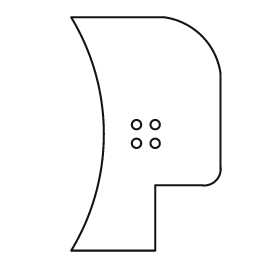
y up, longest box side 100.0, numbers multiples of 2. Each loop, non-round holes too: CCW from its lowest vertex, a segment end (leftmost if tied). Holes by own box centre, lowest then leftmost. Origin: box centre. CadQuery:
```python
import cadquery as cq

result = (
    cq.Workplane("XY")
    .moveTo(-32.0, -50.0)
    .lineTo(4.0, -50.0)
    .lineTo(4.0, -22.0)
    .lineTo(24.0, -22.0)
    .threePointArc((30.0, -20.0), (32.0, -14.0))
    .lineTo(32.0, 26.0)
    .threePointArc((24.0, 42.0), (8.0, 50.0))
    .lineTo(-32.0, 50.0)
    .threePointArc((-18.0, 0.0), (-32.0, -50.0))
    .close()
    .moveTo(-4.0, -4.0)
    .circle(2.0)
    .moveTo(4.0, -4.0)
    .circle(2.0)
    .moveTo(-4.0, 4.0)
    .circle(2.0)
    .moveTo(4.0, 4.0)
    .circle(2.0)
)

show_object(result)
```